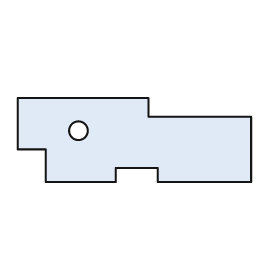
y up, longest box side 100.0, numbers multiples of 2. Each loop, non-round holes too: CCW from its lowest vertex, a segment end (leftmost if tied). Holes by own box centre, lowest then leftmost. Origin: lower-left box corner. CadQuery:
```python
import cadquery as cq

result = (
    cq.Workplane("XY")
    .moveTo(12.0, 0.0)
    .lineTo(42.0, 0.0)
    .lineTo(42.0, 6.0)
    .lineTo(60.0, 6.0)
    .lineTo(60.0, 0.0)
    .lineTo(100.0, 0.0)
    .lineTo(100.0, 28.0)
    .lineTo(56.0, 28.0)
    .lineTo(56.0, 36.0)
    .lineTo(0.0, 36.0)
    .lineTo(0.0, 14.0)
    .lineTo(12.0, 14.0)
    .close()
    .moveTo(26.0, 22.0)
    .circle(4.0)
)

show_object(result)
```